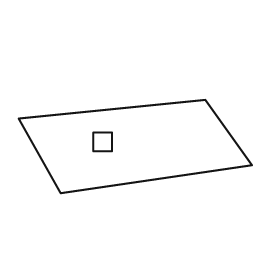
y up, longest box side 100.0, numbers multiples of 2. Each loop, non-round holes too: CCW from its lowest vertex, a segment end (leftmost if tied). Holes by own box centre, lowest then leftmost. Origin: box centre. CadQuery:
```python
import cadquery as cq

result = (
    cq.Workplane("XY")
    .moveTo(-32.0, -20.0)
    .lineTo(50.0, -8.0)
    .lineTo(30.0, 20.0)
    .lineTo(-50.0, 12.0)
    .close()
    .moveTo(-18.0, -2.0)
    .lineTo(-10.0, -2.0)
    .lineTo(-10.0, 6.0)
    .lineTo(-18.0, 6.0)
    .close()
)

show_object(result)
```